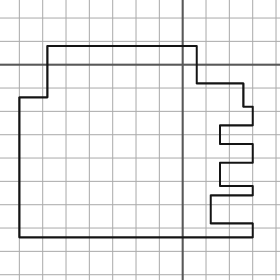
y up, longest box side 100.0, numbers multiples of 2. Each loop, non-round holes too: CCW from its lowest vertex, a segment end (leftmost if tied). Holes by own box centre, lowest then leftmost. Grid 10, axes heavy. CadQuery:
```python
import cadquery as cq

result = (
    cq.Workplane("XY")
    .moveTo(-70.0, -74.0)
    .lineTo(30.0, -74.0)
    .lineTo(30.0, -68.0)
    .lineTo(12.0, -68.0)
    .lineTo(12.0, -56.0)
    .lineTo(30.0, -56.0)
    .lineTo(30.0, -52.0)
    .lineTo(16.0, -52.0)
    .lineTo(16.0, -42.0)
    .lineTo(30.0, -42.0)
    .lineTo(30.0, -34.0)
    .lineTo(16.0, -34.0)
    .lineTo(16.0, -26.0)
    .lineTo(30.0, -26.0)
    .lineTo(30.0, -18.0)
    .lineTo(26.0, -18.0)
    .lineTo(26.0, -8.0)
    .lineTo(6.0, -8.0)
    .lineTo(6.0, 8.0)
    .lineTo(-58.0, 8.0)
    .lineTo(-58.0, -14.0)
    .lineTo(-70.0, -14.0)
    .close()
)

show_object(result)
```